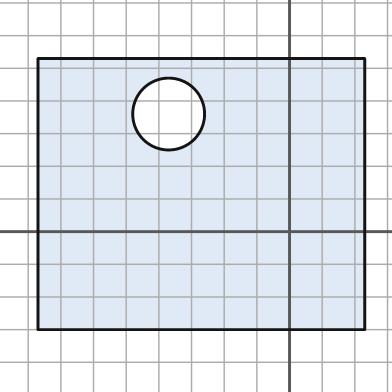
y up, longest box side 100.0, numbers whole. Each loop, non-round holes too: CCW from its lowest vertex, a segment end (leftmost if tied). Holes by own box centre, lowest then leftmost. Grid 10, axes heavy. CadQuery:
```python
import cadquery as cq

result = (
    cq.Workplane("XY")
    .moveTo(-77.0, -30.0)
    .lineTo(23.0, -30.0)
    .lineTo(23.0, 53.0)
    .lineTo(-77.0, 53.0)
    .close()
    .moveTo(-37.0, 36.0)
    .circle(11.0)
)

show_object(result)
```